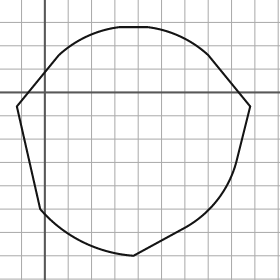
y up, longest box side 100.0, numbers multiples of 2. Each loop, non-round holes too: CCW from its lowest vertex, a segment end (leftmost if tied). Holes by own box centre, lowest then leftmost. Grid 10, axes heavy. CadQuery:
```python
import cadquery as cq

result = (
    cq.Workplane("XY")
    .moveTo(38.0, -70.0)
    .lineTo(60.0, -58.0)
    .threePointArc((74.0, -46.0), (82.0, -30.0))
    .lineTo(88.0, -6.0)
    .lineTo(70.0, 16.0)
    .threePointArc((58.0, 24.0), (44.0, 28.0))
    .lineTo(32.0, 28.0)
    .threePointArc((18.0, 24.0), (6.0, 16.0))
    .lineTo(-12.0, -6.0)
    .lineTo(-2.0, -50.0)
    .threePointArc((16.0, -64.0), (38.0, -70.0))
    .close()
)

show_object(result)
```